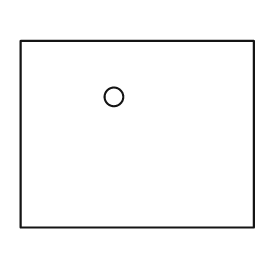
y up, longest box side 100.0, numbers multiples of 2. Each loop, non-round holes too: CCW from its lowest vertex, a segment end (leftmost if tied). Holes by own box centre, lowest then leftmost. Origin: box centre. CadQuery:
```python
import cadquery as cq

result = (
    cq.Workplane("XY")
    .moveTo(-50.0, -40.0)
    .lineTo(50.0, -40.0)
    .lineTo(50.0, 40.0)
    .lineTo(-50.0, 40.0)
    .close()
    .moveTo(-10.0, 16.0)
    .circle(4.0)
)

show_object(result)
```